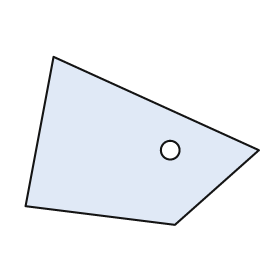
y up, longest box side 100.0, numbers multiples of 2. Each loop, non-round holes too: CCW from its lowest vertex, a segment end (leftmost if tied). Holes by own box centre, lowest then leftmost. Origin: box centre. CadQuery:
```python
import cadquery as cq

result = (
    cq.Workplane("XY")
    .moveTo(14.0, -36.0)
    .lineTo(50.0, -4.0)
    .lineTo(-38.0, 36.0)
    .lineTo(-50.0, -28.0)
    .close()
    .moveTo(12.0, -4.0)
    .circle(4.0)
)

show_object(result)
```